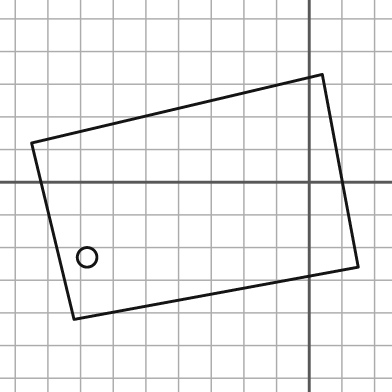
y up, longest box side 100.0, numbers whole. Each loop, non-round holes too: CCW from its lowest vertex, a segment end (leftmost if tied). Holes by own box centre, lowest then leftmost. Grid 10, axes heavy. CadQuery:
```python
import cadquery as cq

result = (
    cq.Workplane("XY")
    .moveTo(-72.0, -42.0)
    .lineTo(15.0, -26.0)
    .lineTo(4.0, 33.0)
    .lineTo(-85.0, 12.0)
    .close()
    .moveTo(-68.0, -23.0)
    .circle(3.0)
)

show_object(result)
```